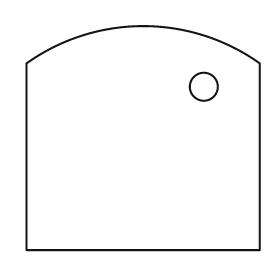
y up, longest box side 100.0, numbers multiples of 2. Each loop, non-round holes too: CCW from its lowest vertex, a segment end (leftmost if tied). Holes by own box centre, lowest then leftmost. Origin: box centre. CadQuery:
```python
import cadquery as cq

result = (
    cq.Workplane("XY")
    .moveTo(-50.0, -48.0)
    .lineTo(50.0, -48.0)
    .lineTo(50.0, 32.0)
    .threePointArc((0.0, 48.0), (-50.0, 32.0))
    .close()
    .moveTo(26.0, 22.0)
    .circle(6.0)
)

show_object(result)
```